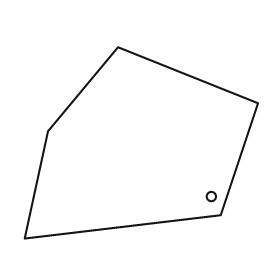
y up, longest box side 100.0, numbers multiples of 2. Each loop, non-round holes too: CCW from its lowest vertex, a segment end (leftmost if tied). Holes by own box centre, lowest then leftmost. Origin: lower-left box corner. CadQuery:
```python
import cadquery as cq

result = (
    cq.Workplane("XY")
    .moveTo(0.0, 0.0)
    .lineTo(84.0, 10.0)
    .lineTo(100.0, 58.0)
    .lineTo(40.0, 82.0)
    .lineTo(10.0, 46.0)
    .close()
    .moveTo(80.0, 18.0)
    .circle(2.0)
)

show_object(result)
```